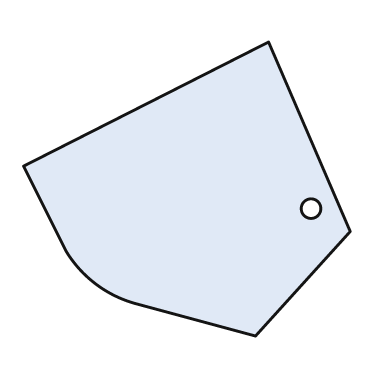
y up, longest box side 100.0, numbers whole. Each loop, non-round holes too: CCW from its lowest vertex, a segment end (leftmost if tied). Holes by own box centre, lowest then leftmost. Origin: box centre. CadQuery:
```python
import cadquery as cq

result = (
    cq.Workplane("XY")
    .moveTo(21.0, -45.0)
    .lineTo(50.0, -13.0)
    .lineTo(25.0, 45.0)
    .lineTo(-50.0, 7.0)
    .lineTo(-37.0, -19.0)
    .threePointArc((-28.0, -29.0), (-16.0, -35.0))
    .close()
    .moveTo(38.0, -6.0)
    .circle(3.0)
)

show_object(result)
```